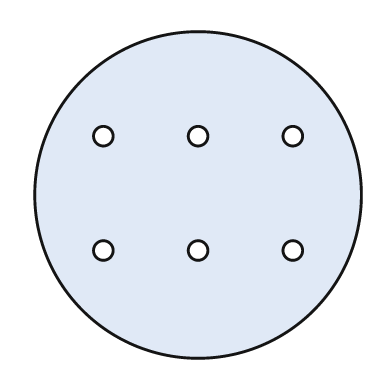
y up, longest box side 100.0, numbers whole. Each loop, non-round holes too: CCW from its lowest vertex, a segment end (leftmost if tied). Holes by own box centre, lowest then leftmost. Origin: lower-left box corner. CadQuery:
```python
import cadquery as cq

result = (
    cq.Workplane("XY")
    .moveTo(50.0, 50.0)
    .circle(50.0)
    .moveTo(21.0, 33.0)
    .circle(3.0)
    .moveTo(50.0, 33.0)
    .circle(3.0)
    .moveTo(79.0, 33.0)
    .circle(3.0)
    .moveTo(21.0, 68.0)
    .circle(3.0)
    .moveTo(50.0, 68.0)
    .circle(3.0)
    .moveTo(79.0, 68.0)
    .circle(3.0)
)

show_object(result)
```